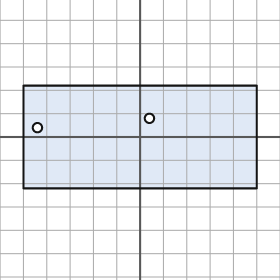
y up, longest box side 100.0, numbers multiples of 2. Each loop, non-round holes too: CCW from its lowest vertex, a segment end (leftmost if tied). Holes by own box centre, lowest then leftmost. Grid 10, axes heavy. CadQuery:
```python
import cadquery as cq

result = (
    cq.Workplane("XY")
    .moveTo(-50.0, -22.0)
    .lineTo(50.0, -22.0)
    .lineTo(50.0, 22.0)
    .lineTo(-50.0, 22.0)
    .close()
    .moveTo(-44.0, 4.0)
    .circle(2.0)
    .moveTo(4.0, 8.0)
    .circle(2.0)
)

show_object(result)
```